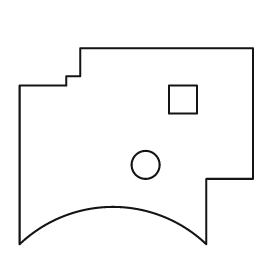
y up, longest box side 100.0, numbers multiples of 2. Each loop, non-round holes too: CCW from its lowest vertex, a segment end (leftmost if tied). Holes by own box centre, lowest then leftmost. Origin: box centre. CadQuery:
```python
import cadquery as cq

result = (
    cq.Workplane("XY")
    .moveTo(-50.0, -42.0)
    .threePointArc((-10.0, -26.0), (30.0, -42.0))
    .lineTo(30.0, -14.0)
    .lineTo(50.0, -14.0)
    .lineTo(50.0, 42.0)
    .lineTo(-24.0, 42.0)
    .lineTo(-24.0, 30.0)
    .lineTo(-30.0, 30.0)
    .lineTo(-30.0, 26.0)
    .lineTo(-50.0, 26.0)
    .close()
    .moveTo(4.0, -8.0)
    .circle(6.0)
    .moveTo(14.0, 14.0)
    .lineTo(26.0, 14.0)
    .lineTo(26.0, 26.0)
    .lineTo(14.0, 26.0)
    .close()
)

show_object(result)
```